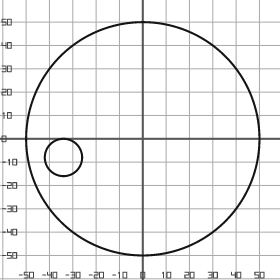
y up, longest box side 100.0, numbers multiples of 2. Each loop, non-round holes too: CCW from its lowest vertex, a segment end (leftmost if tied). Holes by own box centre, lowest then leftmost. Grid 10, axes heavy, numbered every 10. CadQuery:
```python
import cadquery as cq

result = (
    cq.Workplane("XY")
    .moveTo(0.0, 0.0)
    .circle(50.0)
    .moveTo(-34.0, -8.0)
    .circle(8.0)
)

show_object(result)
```